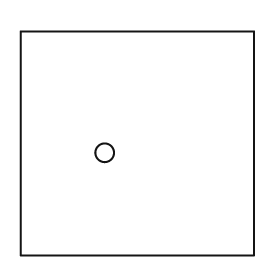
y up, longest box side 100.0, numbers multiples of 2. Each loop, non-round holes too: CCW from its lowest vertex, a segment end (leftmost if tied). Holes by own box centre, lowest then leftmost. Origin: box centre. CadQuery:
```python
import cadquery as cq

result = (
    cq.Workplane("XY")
    .moveTo(-50.0, -48.0)
    .lineTo(50.0, -48.0)
    .lineTo(50.0, 48.0)
    .lineTo(-50.0, 48.0)
    .close()
    .moveTo(-14.0, -4.0)
    .circle(4.0)
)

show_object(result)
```